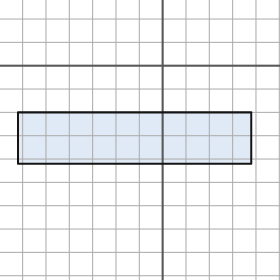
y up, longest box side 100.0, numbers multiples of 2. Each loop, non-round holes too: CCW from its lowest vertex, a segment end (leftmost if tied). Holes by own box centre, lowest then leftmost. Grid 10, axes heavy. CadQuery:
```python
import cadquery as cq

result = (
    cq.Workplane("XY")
    .moveTo(-62.0, -42.0)
    .lineTo(38.0, -42.0)
    .lineTo(38.0, -20.0)
    .lineTo(-62.0, -20.0)
    .close()
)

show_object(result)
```